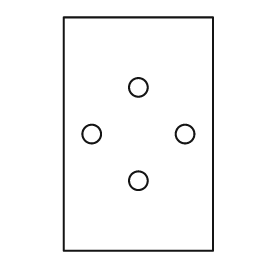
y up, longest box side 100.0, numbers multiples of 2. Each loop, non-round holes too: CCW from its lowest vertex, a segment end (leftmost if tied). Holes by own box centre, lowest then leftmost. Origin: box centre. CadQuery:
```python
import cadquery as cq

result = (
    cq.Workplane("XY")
    .moveTo(-32.0, -50.0)
    .lineTo(32.0, -50.0)
    .lineTo(32.0, 50.0)
    .lineTo(-32.0, 50.0)
    .close()
    .moveTo(0.0, -20.0)
    .circle(4.0)
    .moveTo(-20.0, 0.0)
    .circle(4.0)
    .moveTo(20.0, 0.0)
    .circle(4.0)
    .moveTo(0.0, 20.0)
    .circle(4.0)
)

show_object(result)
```